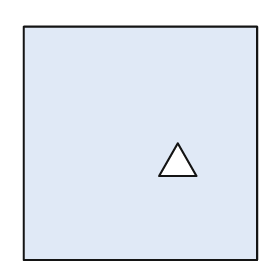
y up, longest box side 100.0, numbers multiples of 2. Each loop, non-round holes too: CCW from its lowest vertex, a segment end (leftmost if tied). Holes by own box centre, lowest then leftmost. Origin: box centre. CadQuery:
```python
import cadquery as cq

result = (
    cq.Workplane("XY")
    .moveTo(-50.0, -50.0)
    .lineTo(50.0, -50.0)
    .lineTo(50.0, 50.0)
    .lineTo(-50.0, 50.0)
    .close()
    .moveTo(8.0, -14.0)
    .lineTo(24.0, -14.0)
    .lineTo(16.0, 0.0)
    .close()
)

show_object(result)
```